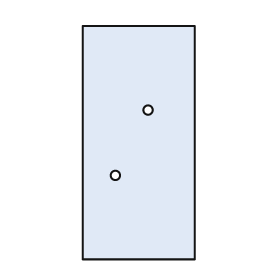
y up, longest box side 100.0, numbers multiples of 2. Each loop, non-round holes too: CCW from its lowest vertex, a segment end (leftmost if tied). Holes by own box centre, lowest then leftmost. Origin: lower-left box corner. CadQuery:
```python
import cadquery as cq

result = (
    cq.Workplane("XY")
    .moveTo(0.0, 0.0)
    .lineTo(48.0, 0.0)
    .lineTo(48.0, 100.0)
    .lineTo(0.0, 100.0)
    .close()
    .moveTo(14.0, 36.0)
    .circle(2.0)
    .moveTo(28.0, 64.0)
    .circle(2.0)
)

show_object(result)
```